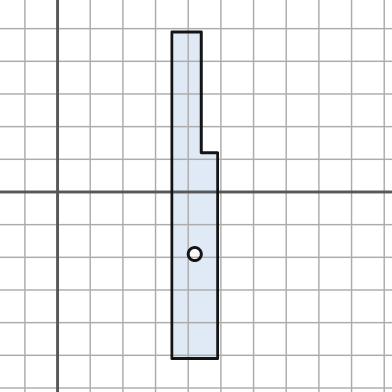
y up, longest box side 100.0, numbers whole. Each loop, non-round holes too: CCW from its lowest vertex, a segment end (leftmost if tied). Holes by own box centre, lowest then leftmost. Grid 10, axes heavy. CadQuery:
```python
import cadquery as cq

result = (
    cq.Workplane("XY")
    .moveTo(35.0, -51.0)
    .lineTo(49.0, -51.0)
    .lineTo(49.0, 12.0)
    .lineTo(44.0, 12.0)
    .lineTo(44.0, 49.0)
    .lineTo(35.0, 49.0)
    .close()
    .moveTo(42.0, -19.0)
    .circle(2.0)
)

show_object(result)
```